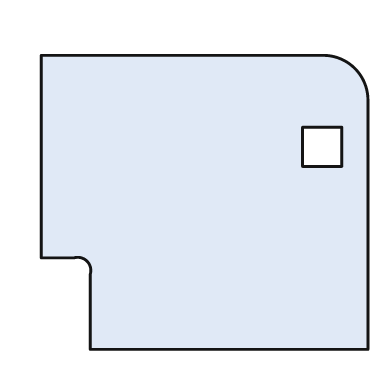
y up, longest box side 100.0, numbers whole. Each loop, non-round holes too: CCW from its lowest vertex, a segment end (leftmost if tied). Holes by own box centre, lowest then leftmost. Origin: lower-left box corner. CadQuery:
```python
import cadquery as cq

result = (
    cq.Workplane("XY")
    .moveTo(15.0, 0.0)
    .lineTo(100.0, 0.0)
    .lineTo(100.0, 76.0)
    .threePointArc((96.0, 86.0), (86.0, 90.0))
    .lineTo(0.0, 90.0)
    .lineTo(0.0, 28.0)
    .lineTo(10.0, 28.0)
    .threePointArc((14.0, 27.0), (15.0, 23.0))
    .close()
    .moveTo(80.0, 56.0)
    .lineTo(92.0, 56.0)
    .lineTo(92.0, 68.0)
    .lineTo(80.0, 68.0)
    .close()
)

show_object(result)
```